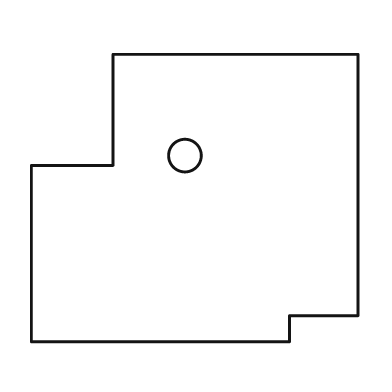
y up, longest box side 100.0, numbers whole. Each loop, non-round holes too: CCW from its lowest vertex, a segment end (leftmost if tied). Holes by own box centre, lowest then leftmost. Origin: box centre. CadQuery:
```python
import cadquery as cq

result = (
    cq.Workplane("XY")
    .moveTo(-50.0, -44.0)
    .lineTo(29.0, -44.0)
    .lineTo(29.0, -36.0)
    .lineTo(50.0, -36.0)
    .lineTo(50.0, 44.0)
    .lineTo(-25.0, 44.0)
    .lineTo(-25.0, 10.0)
    .lineTo(-50.0, 10.0)
    .close()
    .moveTo(-3.0, 13.0)
    .circle(5.0)
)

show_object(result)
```